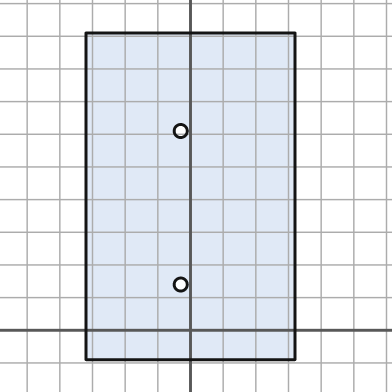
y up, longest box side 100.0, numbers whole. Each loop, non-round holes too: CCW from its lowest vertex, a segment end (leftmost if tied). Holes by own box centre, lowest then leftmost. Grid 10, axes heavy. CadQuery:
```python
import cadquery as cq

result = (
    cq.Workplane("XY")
    .moveTo(-32.0, -9.0)
    .lineTo(32.0, -9.0)
    .lineTo(32.0, 91.0)
    .lineTo(-32.0, 91.0)
    .close()
    .moveTo(-3.0, 14.0)
    .circle(2.0)
    .moveTo(-3.0, 61.0)
    .circle(2.0)
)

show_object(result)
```